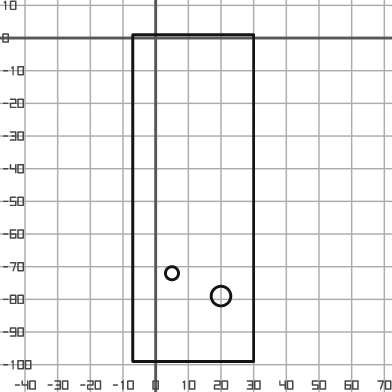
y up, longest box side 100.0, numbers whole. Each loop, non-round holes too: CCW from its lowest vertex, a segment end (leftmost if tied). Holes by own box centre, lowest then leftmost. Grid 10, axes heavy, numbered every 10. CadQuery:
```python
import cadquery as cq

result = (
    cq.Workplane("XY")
    .moveTo(-7.0, -99.0)
    .lineTo(30.0, -99.0)
    .lineTo(30.0, 1.0)
    .lineTo(-7.0, 1.0)
    .close()
    .moveTo(20.0, -79.0)
    .circle(3.0)
    .moveTo(5.0, -72.0)
    .circle(2.0)
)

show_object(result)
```